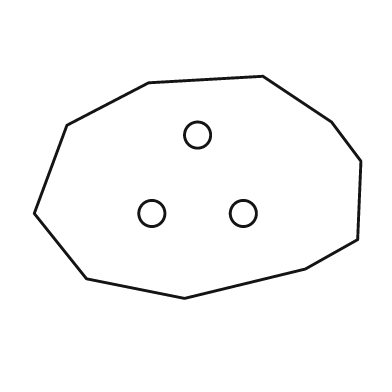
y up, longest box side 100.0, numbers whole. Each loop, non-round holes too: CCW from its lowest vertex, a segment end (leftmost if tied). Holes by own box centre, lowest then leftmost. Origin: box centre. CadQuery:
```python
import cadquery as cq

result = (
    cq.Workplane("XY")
    .moveTo(-4.0, -34.0)
    .lineTo(33.0, -25.0)
    .lineTo(49.0, -16.0)
    .lineTo(50.0, 8.0)
    .lineTo(41.0, 20.0)
    .lineTo(20.0, 34.0)
    .lineTo(-15.0, 32.0)
    .lineTo(-40.0, 19.0)
    .lineTo(-50.0, -8.0)
    .lineTo(-34.0, -28.0)
    .close()
    .moveTo(-14.0, -8.0)
    .circle(4.0)
    .moveTo(14.0, -8.0)
    .circle(4.0)
    .moveTo(0.0, 16.0)
    .circle(4.0)
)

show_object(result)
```